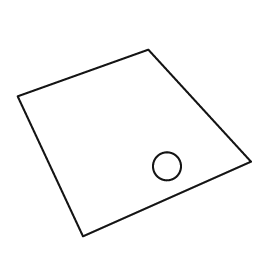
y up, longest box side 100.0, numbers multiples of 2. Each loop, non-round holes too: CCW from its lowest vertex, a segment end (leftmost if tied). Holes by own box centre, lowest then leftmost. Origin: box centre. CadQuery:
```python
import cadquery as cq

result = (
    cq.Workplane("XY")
    .moveTo(-22.0, -40.0)
    .lineTo(50.0, -8.0)
    .lineTo(6.0, 40.0)
    .lineTo(-50.0, 20.0)
    .close()
    .moveTo(14.0, -10.0)
    .circle(6.0)
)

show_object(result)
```